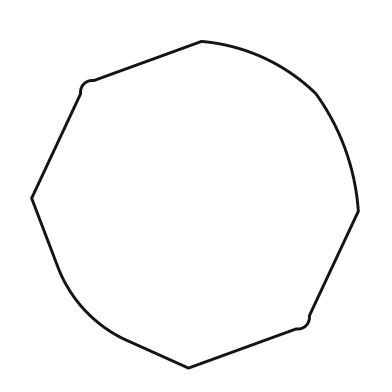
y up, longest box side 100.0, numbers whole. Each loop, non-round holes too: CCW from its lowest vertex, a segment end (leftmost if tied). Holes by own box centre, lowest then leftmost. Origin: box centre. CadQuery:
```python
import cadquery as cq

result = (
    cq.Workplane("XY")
    .moveTo(-2.0, -50.0)
    .lineTo(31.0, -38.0)
    .threePointArc((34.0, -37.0), (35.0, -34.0))
    .lineTo(50.0, -2.0)
    .threePointArc((46.0, 17.0), (37.0, 34.0))
    .threePointArc((21.0, 45.0), (2.0, 50.0))
    .lineTo(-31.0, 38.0)
    .threePointArc((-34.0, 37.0), (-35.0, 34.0))
    .lineTo(-50.0, 2.0)
    .lineTo(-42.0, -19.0)
    .threePointArc((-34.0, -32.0), (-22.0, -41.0))
    .close()
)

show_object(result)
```